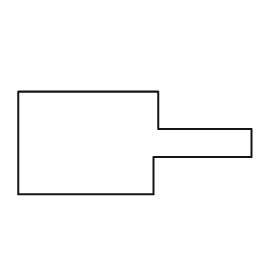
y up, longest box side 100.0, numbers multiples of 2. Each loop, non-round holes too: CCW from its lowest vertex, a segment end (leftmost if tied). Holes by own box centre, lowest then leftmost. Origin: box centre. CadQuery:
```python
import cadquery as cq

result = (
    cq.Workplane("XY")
    .moveTo(-50.0, -22.0)
    .lineTo(8.0, -22.0)
    .lineTo(8.0, -6.0)
    .lineTo(50.0, -6.0)
    .lineTo(50.0, 6.0)
    .lineTo(10.0, 6.0)
    .lineTo(10.0, 22.0)
    .lineTo(-50.0, 22.0)
    .close()
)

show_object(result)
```